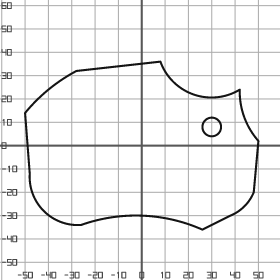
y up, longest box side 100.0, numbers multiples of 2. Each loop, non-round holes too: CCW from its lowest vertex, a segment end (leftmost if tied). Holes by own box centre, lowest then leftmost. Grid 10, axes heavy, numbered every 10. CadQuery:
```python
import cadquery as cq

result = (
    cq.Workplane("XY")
    .moveTo(26.0, -36.0)
    .lineTo(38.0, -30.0)
    .threePointArc((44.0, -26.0), (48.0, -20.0))
    .lineTo(50.0, 2.0)
    .threePointArc((44.0, 12.0), (42.0, 24.0))
    .threePointArc((22.0, 22.0), (8.0, 36.0))
    .lineTo(-28.0, 32.0)
    .threePointArc((-40.0, 24.0), (-50.0, 14.0))
    .lineTo(-48.0, -12.0)
    .threePointArc((-42.0, -28.0), (-26.0, -34.0))
    .threePointArc((0.0, -30.0), (26.0, -36.0))
    .close()
    .moveTo(30.0, 8.0)
    .circle(4.0)
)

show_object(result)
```